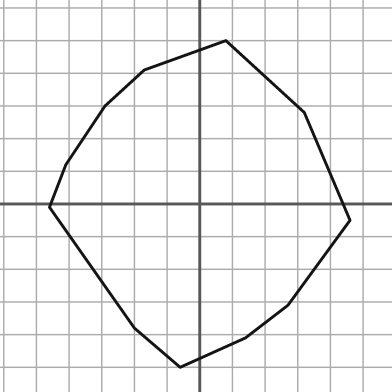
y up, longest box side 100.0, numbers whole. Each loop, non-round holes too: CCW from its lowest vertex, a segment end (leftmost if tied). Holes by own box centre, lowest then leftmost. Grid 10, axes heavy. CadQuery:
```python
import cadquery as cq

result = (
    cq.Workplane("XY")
    .moveTo(-6.0, -50.0)
    .lineTo(14.0, -41.0)
    .lineTo(27.0, -31.0)
    .lineTo(46.0, -5.0)
    .lineTo(32.0, 28.0)
    .lineTo(8.0, 50.0)
    .lineTo(-17.0, 41.0)
    .lineTo(-29.0, 30.0)
    .lineTo(-41.0, 12.0)
    .lineTo(-46.0, -1.0)
    .lineTo(-20.0, -38.0)
    .close()
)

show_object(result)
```